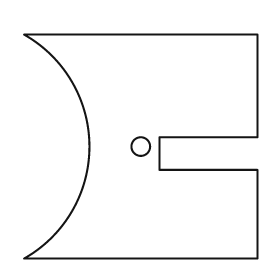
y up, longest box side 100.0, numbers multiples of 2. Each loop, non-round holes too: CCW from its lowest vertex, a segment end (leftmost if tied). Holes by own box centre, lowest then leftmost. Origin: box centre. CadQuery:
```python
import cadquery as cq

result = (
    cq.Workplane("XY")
    .moveTo(-50.0, -48.0)
    .lineTo(50.0, -48.0)
    .lineTo(50.0, -10.0)
    .lineTo(8.0, -10.0)
    .lineTo(8.0, 4.0)
    .lineTo(50.0, 4.0)
    .lineTo(50.0, 48.0)
    .lineTo(-50.0, 48.0)
    .threePointArc((-22.0, 0.0), (-50.0, -48.0))
    .close()
    .moveTo(0.0, 0.0)
    .circle(4.0)
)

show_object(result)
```